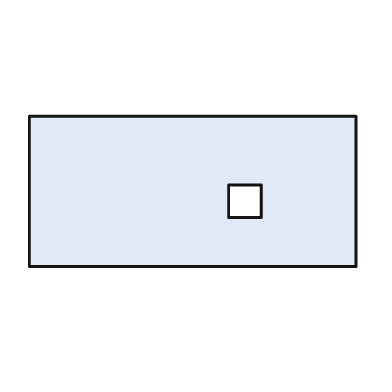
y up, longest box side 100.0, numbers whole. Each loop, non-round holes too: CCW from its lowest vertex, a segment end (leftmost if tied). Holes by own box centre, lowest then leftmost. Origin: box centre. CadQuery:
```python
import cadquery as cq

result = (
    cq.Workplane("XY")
    .moveTo(-50.0, -23.0)
    .lineTo(50.0, -23.0)
    .lineTo(50.0, 23.0)
    .lineTo(-50.0, 23.0)
    .close()
    .moveTo(11.0, -8.0)
    .lineTo(21.0, -8.0)
    .lineTo(21.0, 2.0)
    .lineTo(11.0, 2.0)
    .close()
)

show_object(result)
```